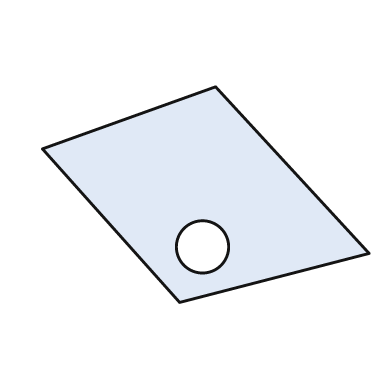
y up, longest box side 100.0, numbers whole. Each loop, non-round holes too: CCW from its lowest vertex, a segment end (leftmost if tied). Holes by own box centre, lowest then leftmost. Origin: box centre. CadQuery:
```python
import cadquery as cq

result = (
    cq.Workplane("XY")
    .moveTo(-8.0, -33.0)
    .lineTo(50.0, -18.0)
    .lineTo(3.0, 33.0)
    .lineTo(-50.0, 14.0)
    .close()
    .moveTo(-1.0, -16.0)
    .circle(8.0)
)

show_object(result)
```